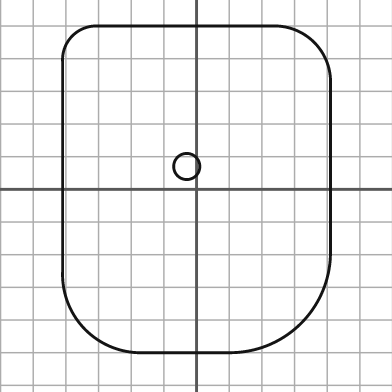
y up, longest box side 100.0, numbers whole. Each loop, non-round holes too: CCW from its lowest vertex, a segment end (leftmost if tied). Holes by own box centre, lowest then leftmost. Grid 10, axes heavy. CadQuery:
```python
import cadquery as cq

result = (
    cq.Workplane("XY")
    .moveTo(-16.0, -50.0)
    .lineTo(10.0, -50.0)
    .threePointArc((32.0, -41.0), (41.0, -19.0))
    .lineTo(41.0, 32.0)
    .threePointArc((36.0, 45.0), (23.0, 50.0))
    .lineTo(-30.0, 50.0)
    .threePointArc((-38.0, 47.0), (-41.0, 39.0))
    .lineTo(-41.0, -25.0)
    .threePointArc((-34.0, -43.0), (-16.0, -50.0))
    .close()
    .moveTo(-3.0, 7.0)
    .circle(4.0)
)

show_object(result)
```